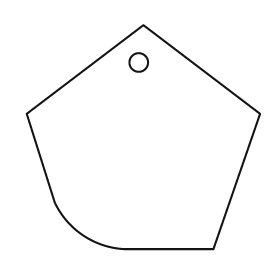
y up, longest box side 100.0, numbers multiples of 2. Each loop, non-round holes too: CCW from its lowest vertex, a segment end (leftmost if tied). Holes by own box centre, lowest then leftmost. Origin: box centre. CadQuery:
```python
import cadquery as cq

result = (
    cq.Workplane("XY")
    .moveTo(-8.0, -48.0)
    .lineTo(30.0, -48.0)
    .lineTo(50.0, 10.0)
    .lineTo(0.0, 48.0)
    .lineTo(-50.0, 10.0)
    .lineTo(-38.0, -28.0)
    .threePointArc((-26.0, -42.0), (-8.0, -48.0))
    .close()
    .moveTo(-2.0, 32.0)
    .circle(4.0)
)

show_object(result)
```